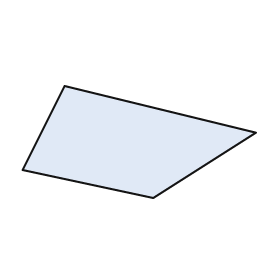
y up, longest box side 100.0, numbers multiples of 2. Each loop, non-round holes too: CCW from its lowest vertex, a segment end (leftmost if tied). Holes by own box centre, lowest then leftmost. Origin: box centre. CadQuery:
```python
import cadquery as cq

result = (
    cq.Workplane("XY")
    .moveTo(6.0, -24.0)
    .lineTo(50.0, 4.0)
    .lineTo(-32.0, 24.0)
    .lineTo(-50.0, -12.0)
    .close()
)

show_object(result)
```